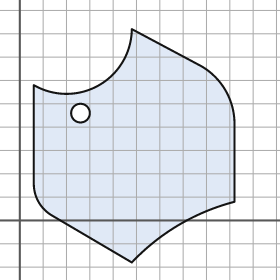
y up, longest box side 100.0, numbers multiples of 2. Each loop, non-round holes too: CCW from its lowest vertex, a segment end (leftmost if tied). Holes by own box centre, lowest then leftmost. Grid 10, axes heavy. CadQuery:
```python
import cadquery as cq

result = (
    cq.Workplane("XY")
    .moveTo(48.0, -18.0)
    .threePointArc((68.0, -2.0), (92.0, 8.0))
    .lineTo(92.0, 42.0)
    .threePointArc((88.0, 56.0), (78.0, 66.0))
    .lineTo(48.0, 82.0)
    .threePointArc((34.0, 58.0), (6.0, 58.0))
    .lineTo(6.0, 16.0)
    .threePointArc((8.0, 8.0), (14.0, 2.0))
    .close()
    .moveTo(26.0, 46.0)
    .circle(4.0)
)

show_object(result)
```